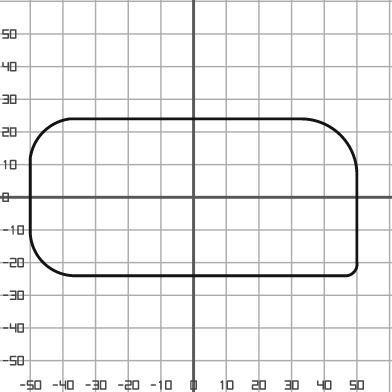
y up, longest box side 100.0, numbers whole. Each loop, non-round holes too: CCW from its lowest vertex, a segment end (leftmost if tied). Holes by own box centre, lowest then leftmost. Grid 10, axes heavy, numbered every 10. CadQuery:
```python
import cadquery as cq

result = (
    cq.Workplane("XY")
    .moveTo(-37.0, -24.0)
    .lineTo(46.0, -24.0)
    .threePointArc((49.0, -23.0), (50.0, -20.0))
    .lineTo(50.0, 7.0)
    .threePointArc((45.0, 19.0), (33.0, 24.0))
    .lineTo(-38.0, 24.0)
    .threePointArc((-46.0, 20.0), (-50.0, 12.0))
    .lineTo(-50.0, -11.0)
    .threePointArc((-46.0, -20.0), (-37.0, -24.0))
    .close()
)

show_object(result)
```